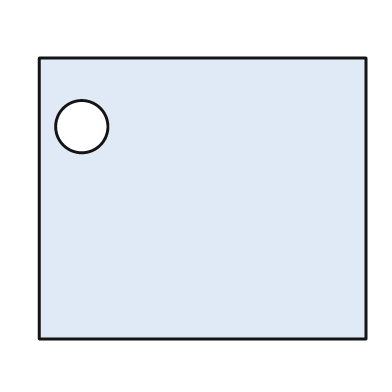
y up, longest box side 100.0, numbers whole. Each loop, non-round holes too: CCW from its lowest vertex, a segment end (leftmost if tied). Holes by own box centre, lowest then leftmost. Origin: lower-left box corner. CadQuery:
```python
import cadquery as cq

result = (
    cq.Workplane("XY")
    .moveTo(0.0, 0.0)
    .lineTo(100.0, 0.0)
    .lineTo(100.0, 86.0)
    .lineTo(0.0, 86.0)
    .close()
    .moveTo(13.0, 65.0)
    .circle(8.0)
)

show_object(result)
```